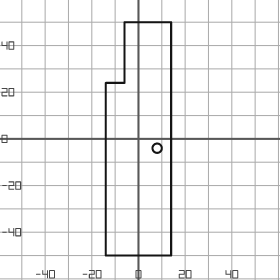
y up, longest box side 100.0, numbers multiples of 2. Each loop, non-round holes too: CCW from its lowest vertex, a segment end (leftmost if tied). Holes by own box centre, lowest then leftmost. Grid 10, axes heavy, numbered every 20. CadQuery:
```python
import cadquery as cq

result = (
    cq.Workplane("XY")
    .moveTo(-14.0, -50.0)
    .lineTo(14.0, -50.0)
    .lineTo(14.0, 50.0)
    .lineTo(-6.0, 50.0)
    .lineTo(-6.0, 24.0)
    .lineTo(-14.0, 24.0)
    .close()
    .moveTo(8.0, -4.0)
    .circle(2.0)
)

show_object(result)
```